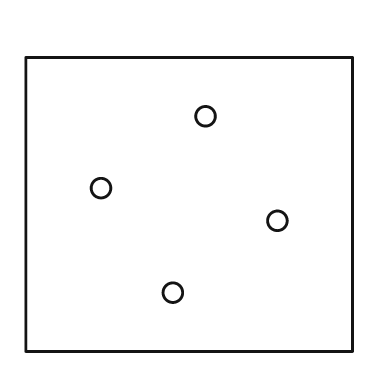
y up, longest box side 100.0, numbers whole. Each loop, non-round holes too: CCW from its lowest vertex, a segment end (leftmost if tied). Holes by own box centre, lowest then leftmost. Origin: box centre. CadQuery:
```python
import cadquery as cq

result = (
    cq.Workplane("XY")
    .moveTo(-50.0, -45.0)
    .lineTo(50.0, -45.0)
    .lineTo(50.0, 45.0)
    .lineTo(-50.0, 45.0)
    .close()
    .moveTo(-5.0, -27.0)
    .circle(3.0)
    .moveTo(27.0, -5.0)
    .circle(3.0)
    .moveTo(-27.0, 5.0)
    .circle(3.0)
    .moveTo(5.0, 27.0)
    .circle(3.0)
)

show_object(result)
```